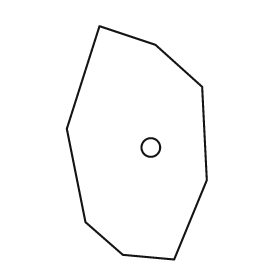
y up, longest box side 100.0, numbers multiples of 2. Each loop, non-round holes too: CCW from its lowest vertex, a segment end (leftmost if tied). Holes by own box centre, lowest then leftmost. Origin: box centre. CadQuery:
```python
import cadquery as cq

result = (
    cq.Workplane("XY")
    .moveTo(16.0, -50.0)
    .lineTo(30.0, -16.0)
    .lineTo(28.0, 24.0)
    .lineTo(8.0, 42.0)
    .lineTo(-16.0, 50.0)
    .lineTo(-30.0, 6.0)
    .lineTo(-22.0, -34.0)
    .lineTo(-6.0, -48.0)
    .close()
    .moveTo(6.0, -2.0)
    .circle(4.0)
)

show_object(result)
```